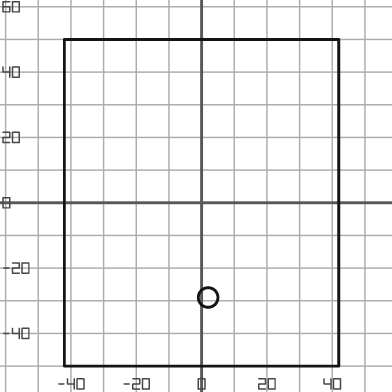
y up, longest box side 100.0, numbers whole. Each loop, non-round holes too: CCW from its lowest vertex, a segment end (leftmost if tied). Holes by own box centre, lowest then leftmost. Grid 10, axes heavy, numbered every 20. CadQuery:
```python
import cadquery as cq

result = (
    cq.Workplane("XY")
    .moveTo(-42.0, -50.0)
    .lineTo(42.0, -50.0)
    .lineTo(42.0, 50.0)
    .lineTo(-42.0, 50.0)
    .close()
    .moveTo(2.0, -29.0)
    .circle(3.0)
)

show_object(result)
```